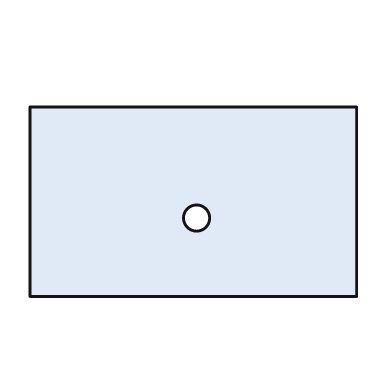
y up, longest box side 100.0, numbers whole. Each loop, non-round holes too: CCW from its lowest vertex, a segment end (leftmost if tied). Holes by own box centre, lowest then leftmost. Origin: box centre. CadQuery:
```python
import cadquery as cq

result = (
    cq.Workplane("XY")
    .moveTo(-50.0, -29.0)
    .lineTo(50.0, -29.0)
    .lineTo(50.0, 29.0)
    .lineTo(-50.0, 29.0)
    .close()
    .moveTo(1.0, -5.0)
    .circle(4.0)
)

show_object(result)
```